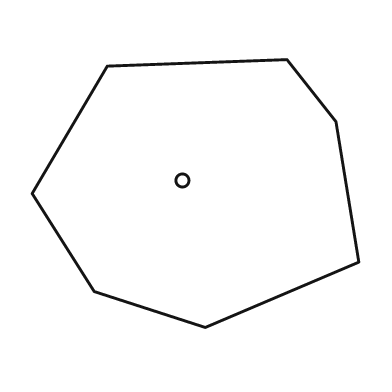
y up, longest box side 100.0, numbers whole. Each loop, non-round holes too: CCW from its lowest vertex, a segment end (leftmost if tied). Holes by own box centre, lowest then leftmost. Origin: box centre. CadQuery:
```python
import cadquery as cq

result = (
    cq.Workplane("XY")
    .moveTo(3.0, -41.0)
    .lineTo(50.0, -21.0)
    .lineTo(43.0, 22.0)
    .lineTo(28.0, 41.0)
    .lineTo(-27.0, 39.0)
    .lineTo(-50.0, 0.0)
    .lineTo(-31.0, -30.0)
    .close()
    .moveTo(-4.0, 4.0)
    .circle(2.0)
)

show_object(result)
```